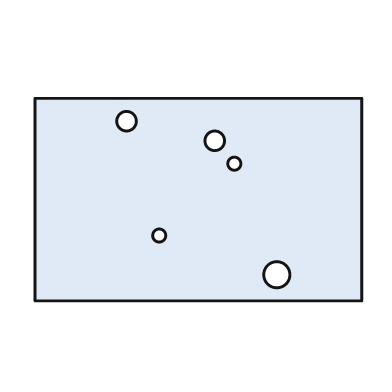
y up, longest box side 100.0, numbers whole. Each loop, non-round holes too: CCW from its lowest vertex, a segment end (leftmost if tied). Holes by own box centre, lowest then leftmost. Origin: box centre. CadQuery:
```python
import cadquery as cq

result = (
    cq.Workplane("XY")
    .moveTo(-50.0, -31.0)
    .lineTo(50.0, -31.0)
    .lineTo(50.0, 31.0)
    .lineTo(-50.0, 31.0)
    .close()
    .moveTo(24.0, -23.0)
    .circle(4.0)
    .moveTo(-12.0, -11.0)
    .circle(2.0)
    .moveTo(11.0, 11.0)
    .circle(2.0)
    .moveTo(5.0, 18.0)
    .circle(3.0)
    .moveTo(-22.0, 24.0)
    .circle(3.0)
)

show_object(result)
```